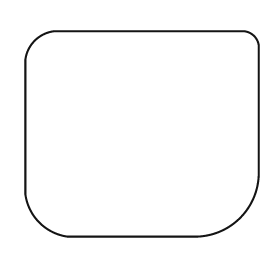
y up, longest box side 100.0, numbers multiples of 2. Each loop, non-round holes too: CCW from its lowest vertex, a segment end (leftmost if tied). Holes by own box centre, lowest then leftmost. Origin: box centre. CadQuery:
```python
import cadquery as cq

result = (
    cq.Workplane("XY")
    .moveTo(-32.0, -44.0)
    .lineTo(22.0, -44.0)
    .threePointArc((42.0, -36.0), (50.0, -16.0))
    .lineTo(50.0, 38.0)
    .threePointArc((48.0, 42.0), (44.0, 44.0))
    .lineTo(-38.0, 44.0)
    .threePointArc((-46.0, 40.0), (-50.0, 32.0))
    .lineTo(-50.0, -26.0)
    .threePointArc((-44.0, -38.0), (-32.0, -44.0))
    .close()
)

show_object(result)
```